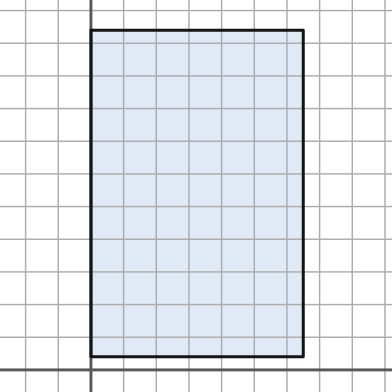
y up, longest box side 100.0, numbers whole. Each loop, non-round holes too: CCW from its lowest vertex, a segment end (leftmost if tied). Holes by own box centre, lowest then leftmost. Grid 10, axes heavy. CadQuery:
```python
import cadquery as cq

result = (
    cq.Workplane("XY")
    .moveTo(0.0, 4.0)
    .lineTo(65.0, 4.0)
    .lineTo(65.0, 104.0)
    .lineTo(0.0, 104.0)
    .close()
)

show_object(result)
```